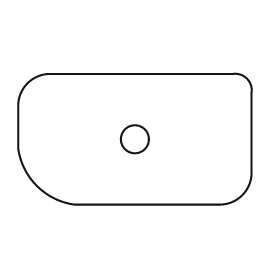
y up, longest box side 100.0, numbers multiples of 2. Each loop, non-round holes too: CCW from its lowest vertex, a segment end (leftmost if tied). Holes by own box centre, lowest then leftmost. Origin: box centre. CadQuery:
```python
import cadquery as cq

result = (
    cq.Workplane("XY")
    .moveTo(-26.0, -28.0)
    .lineTo(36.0, -28.0)
    .threePointArc((46.0, -24.0), (50.0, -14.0))
    .lineTo(50.0, 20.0)
    .threePointArc((48.0, 26.0), (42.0, 28.0))
    .lineTo(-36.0, 28.0)
    .threePointArc((-46.0, 24.0), (-50.0, 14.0))
    .lineTo(-50.0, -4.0)
    .threePointArc((-42.0, -20.0), (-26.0, -28.0))
    .close()
    .moveTo(0.0, 0.0)
    .circle(6.0)
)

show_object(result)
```